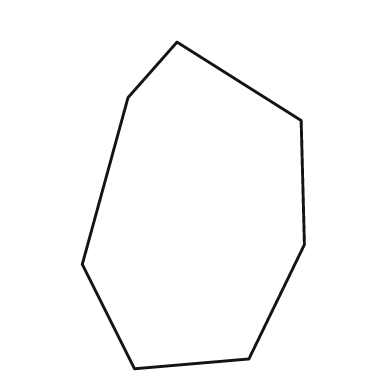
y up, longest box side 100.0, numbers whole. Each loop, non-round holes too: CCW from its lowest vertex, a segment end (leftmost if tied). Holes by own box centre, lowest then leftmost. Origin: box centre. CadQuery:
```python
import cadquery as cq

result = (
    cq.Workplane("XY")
    .moveTo(-18.0, -50.0)
    .lineTo(17.0, -47.0)
    .lineTo(34.0, -12.0)
    .lineTo(33.0, 26.0)
    .lineTo(-5.0, 50.0)
    .lineTo(-20.0, 33.0)
    .lineTo(-34.0, -18.0)
    .close()
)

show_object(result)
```